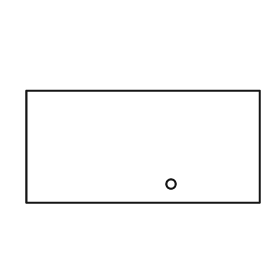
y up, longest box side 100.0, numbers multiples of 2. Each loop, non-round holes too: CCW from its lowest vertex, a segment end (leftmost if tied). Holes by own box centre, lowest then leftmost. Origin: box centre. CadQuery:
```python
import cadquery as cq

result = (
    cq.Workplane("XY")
    .moveTo(-50.0, -24.0)
    .lineTo(50.0, -24.0)
    .lineTo(50.0, 24.0)
    .lineTo(-50.0, 24.0)
    .close()
    .moveTo(12.0, -16.0)
    .circle(2.0)
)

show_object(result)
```